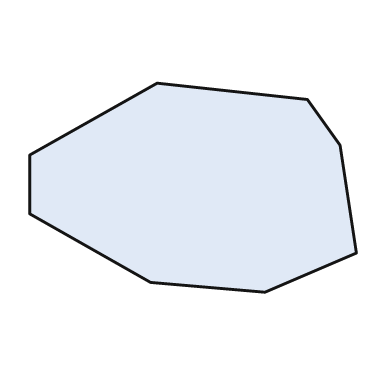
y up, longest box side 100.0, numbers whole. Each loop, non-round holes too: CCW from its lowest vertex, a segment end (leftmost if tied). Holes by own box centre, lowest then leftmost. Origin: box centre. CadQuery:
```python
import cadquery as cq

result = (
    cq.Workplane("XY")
    .moveTo(22.0, -32.0)
    .lineTo(50.0, -20.0)
    .lineTo(45.0, 13.0)
    .lineTo(35.0, 27.0)
    .lineTo(-11.0, 32.0)
    .lineTo(-50.0, 10.0)
    .lineTo(-50.0, -8.0)
    .lineTo(-13.0, -29.0)
    .close()
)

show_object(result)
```